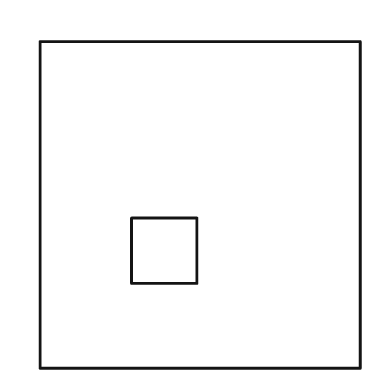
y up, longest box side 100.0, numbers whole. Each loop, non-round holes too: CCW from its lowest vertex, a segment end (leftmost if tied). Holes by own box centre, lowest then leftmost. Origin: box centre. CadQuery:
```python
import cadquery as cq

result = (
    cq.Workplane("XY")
    .moveTo(-49.0, -50.0)
    .lineTo(49.0, -50.0)
    .lineTo(49.0, 50.0)
    .lineTo(-49.0, 50.0)
    .close()
    .moveTo(-21.0, -24.0)
    .lineTo(-1.0, -24.0)
    .lineTo(-1.0, -4.0)
    .lineTo(-21.0, -4.0)
    .close()
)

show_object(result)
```